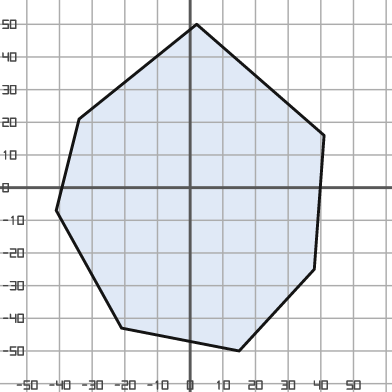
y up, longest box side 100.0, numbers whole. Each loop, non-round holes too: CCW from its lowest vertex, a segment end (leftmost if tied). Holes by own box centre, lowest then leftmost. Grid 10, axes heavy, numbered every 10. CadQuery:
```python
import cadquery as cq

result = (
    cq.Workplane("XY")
    .moveTo(15.0, -50.0)
    .lineTo(38.0, -25.0)
    .lineTo(41.0, 16.0)
    .lineTo(2.0, 50.0)
    .lineTo(-34.0, 21.0)
    .lineTo(-41.0, -7.0)
    .lineTo(-21.0, -43.0)
    .close()
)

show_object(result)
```